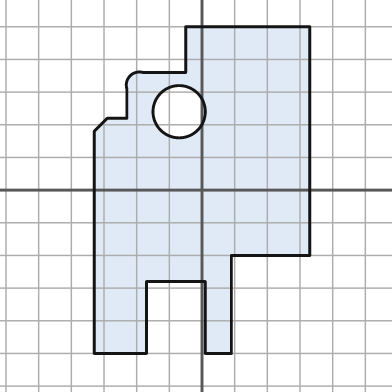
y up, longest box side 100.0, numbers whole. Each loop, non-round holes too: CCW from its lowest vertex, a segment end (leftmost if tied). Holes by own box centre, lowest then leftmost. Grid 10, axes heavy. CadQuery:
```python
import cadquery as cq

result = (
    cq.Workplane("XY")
    .moveTo(-33.0, -50.0)
    .lineTo(-17.0, -50.0)
    .lineTo(-17.0, -28.0)
    .lineTo(1.0, -28.0)
    .lineTo(1.0, -50.0)
    .lineTo(9.0, -50.0)
    .lineTo(9.0, -20.0)
    .lineTo(33.0, -20.0)
    .lineTo(33.0, 50.0)
    .lineTo(-5.0, 50.0)
    .lineTo(-5.0, 36.0)
    .lineTo(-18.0, 36.0)
    .threePointArc((-22.0, 35.0), (-23.0, 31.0))
    .lineTo(-23.0, 22.0)
    .lineTo(-29.0, 22.0)
    .lineTo(-33.0, 18.0)
    .close()
    .moveTo(-7.0, 24.0)
    .circle(8.0)
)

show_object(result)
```